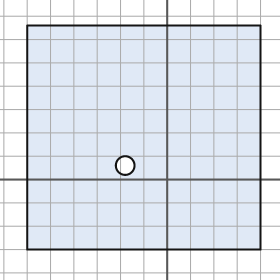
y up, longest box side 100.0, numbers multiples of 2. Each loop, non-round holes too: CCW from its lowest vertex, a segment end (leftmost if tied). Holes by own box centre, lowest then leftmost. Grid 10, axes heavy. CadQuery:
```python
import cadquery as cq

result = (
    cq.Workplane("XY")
    .moveTo(-60.0, -30.0)
    .lineTo(40.0, -30.0)
    .lineTo(40.0, 66.0)
    .lineTo(-60.0, 66.0)
    .close()
    .moveTo(-18.0, 6.0)
    .circle(4.0)
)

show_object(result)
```